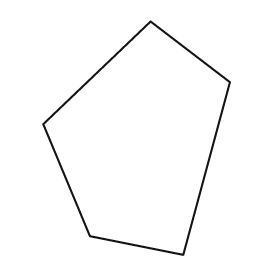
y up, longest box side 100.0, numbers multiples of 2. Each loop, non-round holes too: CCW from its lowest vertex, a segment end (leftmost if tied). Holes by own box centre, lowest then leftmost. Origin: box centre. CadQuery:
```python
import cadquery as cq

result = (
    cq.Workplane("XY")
    .moveTo(20.0, -50.0)
    .lineTo(40.0, 24.0)
    .lineTo(6.0, 50.0)
    .lineTo(-40.0, 6.0)
    .lineTo(-20.0, -42.0)
    .close()
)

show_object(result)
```